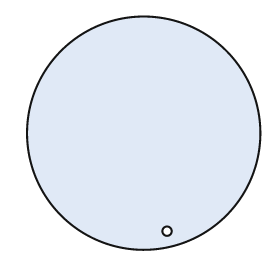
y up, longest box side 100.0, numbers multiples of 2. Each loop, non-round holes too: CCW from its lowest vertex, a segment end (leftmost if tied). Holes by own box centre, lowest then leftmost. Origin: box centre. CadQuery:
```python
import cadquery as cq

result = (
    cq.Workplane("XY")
    .moveTo(0.0, 0.0)
    .circle(50.0)
    .moveTo(10.0, -42.0)
    .circle(2.0)
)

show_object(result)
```